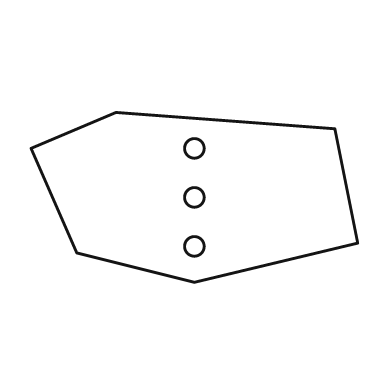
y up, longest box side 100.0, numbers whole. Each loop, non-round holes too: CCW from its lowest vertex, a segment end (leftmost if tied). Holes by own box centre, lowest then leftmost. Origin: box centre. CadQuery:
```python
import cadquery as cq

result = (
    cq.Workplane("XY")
    .moveTo(0.0, -26.0)
    .lineTo(50.0, -14.0)
    .lineTo(43.0, 21.0)
    .lineTo(-24.0, 26.0)
    .lineTo(-50.0, 15.0)
    .lineTo(-36.0, -17.0)
    .close()
    .moveTo(0.0, -15.0)
    .circle(3.0)
    .moveTo(0.0, 0.0)
    .circle(3.0)
    .moveTo(0.0, 15.0)
    .circle(3.0)
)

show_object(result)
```